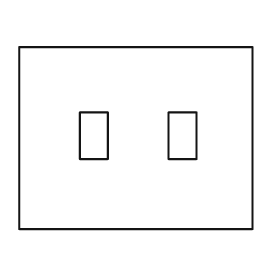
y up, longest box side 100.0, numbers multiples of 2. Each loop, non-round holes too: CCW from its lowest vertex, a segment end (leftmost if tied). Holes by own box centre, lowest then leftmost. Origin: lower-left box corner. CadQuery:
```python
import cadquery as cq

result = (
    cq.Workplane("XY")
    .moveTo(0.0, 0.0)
    .lineTo(100.0, 0.0)
    .lineTo(100.0, 78.0)
    .lineTo(0.0, 78.0)
    .close()
    .moveTo(26.0, 30.0)
    .lineTo(38.0, 30.0)
    .lineTo(38.0, 50.0)
    .lineTo(26.0, 50.0)
    .close()
    .moveTo(64.0, 30.0)
    .lineTo(76.0, 30.0)
    .lineTo(76.0, 50.0)
    .lineTo(64.0, 50.0)
    .close()
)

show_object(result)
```